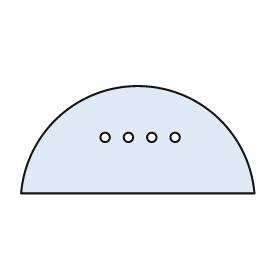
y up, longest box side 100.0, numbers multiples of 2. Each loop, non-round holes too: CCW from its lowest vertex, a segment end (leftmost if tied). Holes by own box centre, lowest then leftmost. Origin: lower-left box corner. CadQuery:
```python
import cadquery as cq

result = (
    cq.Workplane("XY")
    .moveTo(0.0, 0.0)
    .lineTo(100.0, 0.0)
    .threePointArc((50.0, 46.0), (0.0, 0.0))
    .close()
    .moveTo(36.0, 24.0)
    .circle(2.0)
    .moveTo(46.0, 24.0)
    .circle(2.0)
    .moveTo(56.0, 24.0)
    .circle(2.0)
    .moveTo(66.0, 24.0)
    .circle(2.0)
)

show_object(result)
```